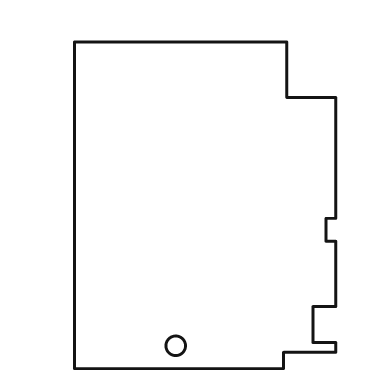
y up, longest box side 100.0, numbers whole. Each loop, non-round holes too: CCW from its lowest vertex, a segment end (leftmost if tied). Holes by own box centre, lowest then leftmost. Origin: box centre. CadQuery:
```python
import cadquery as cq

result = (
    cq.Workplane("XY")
    .moveTo(-40.0, -50.0)
    .lineTo(24.0, -50.0)
    .lineTo(24.0, -45.0)
    .lineTo(40.0, -45.0)
    .lineTo(40.0, -42.0)
    .lineTo(33.0, -42.0)
    .lineTo(33.0, -31.0)
    .lineTo(40.0, -31.0)
    .lineTo(40.0, -11.0)
    .lineTo(37.0, -11.0)
    .lineTo(37.0, -4.0)
    .lineTo(40.0, -4.0)
    .lineTo(40.0, 33.0)
    .lineTo(25.0, 33.0)
    .lineTo(25.0, 50.0)
    .lineTo(-40.0, 50.0)
    .close()
    .moveTo(-9.0, -43.0)
    .circle(3.0)
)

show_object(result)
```